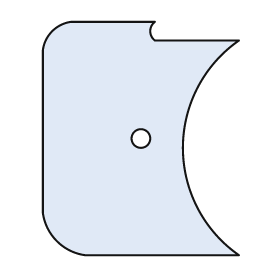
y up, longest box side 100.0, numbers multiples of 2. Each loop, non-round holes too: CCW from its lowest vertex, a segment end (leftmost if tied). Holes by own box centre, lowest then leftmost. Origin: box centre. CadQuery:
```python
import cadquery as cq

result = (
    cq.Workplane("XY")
    .moveTo(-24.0, -50.0)
    .lineTo(42.0, -50.0)
    .threePointArc((18.0, -4.0), (42.0, 42.0))
    .lineTo(6.0, 42.0)
    .threePointArc((4.0, 46.0), (6.0, 50.0))
    .lineTo(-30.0, 50.0)
    .threePointArc((-38.0, 46.0), (-42.0, 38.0))
    .lineTo(-42.0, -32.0)
    .threePointArc((-36.0, -44.0), (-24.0, -50.0))
    .close()
    .moveTo(0.0, 0.0)
    .circle(4.0)
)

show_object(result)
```